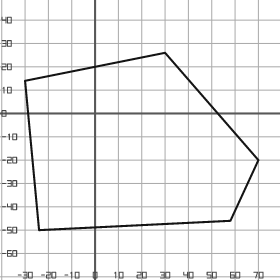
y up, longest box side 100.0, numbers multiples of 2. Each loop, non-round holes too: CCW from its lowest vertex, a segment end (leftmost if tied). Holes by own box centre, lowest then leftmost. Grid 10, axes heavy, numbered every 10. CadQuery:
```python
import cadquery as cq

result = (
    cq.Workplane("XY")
    .moveTo(-24.0, -50.0)
    .lineTo(58.0, -46.0)
    .lineTo(70.0, -20.0)
    .lineTo(30.0, 26.0)
    .lineTo(-30.0, 14.0)
    .close()
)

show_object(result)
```